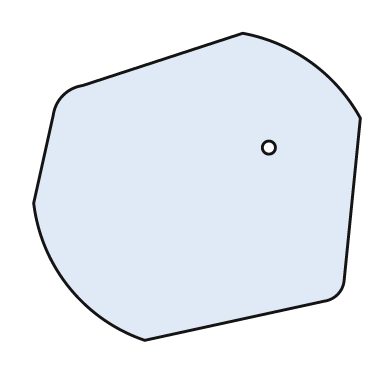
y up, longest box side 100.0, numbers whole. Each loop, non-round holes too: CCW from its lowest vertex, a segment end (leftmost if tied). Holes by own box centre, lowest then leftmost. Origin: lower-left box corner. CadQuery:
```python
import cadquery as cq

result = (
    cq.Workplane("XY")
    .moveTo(34.0, 0.0)
    .lineTo(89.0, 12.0)
    .threePointArc((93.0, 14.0), (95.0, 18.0))
    .lineTo(100.0, 68.0)
    .threePointArc((85.0, 85.0), (64.0, 94.0))
    .lineTo(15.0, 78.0)
    .threePointArc((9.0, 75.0), (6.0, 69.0))
    .lineTo(0.0, 42.0)
    .threePointArc((11.0, 16.0), (34.0, 0.0))
    .close()
    .moveTo(72.0, 59.0)
    .circle(2.0)
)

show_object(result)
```